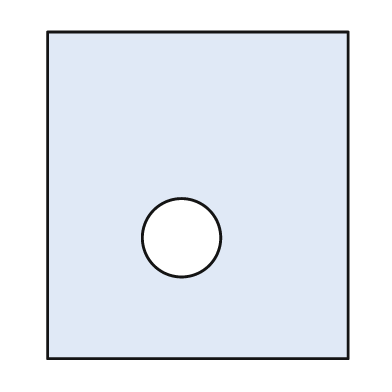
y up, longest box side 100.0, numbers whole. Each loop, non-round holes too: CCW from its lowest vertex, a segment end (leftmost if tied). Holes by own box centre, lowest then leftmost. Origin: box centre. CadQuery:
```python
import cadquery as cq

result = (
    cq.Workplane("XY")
    .moveTo(-46.0, -50.0)
    .lineTo(46.0, -50.0)
    .lineTo(46.0, 50.0)
    .lineTo(-46.0, 50.0)
    .close()
    .moveTo(-5.0, -13.0)
    .circle(12.0)
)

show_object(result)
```